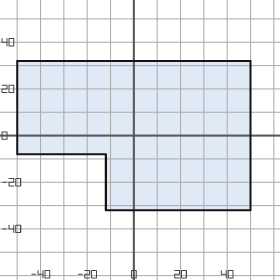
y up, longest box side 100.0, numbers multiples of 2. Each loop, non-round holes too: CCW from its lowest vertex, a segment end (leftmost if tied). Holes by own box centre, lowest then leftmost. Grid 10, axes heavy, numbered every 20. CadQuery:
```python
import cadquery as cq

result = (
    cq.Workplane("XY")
    .moveTo(-12.0, -32.0)
    .lineTo(50.0, -32.0)
    .lineTo(50.0, 32.0)
    .lineTo(-50.0, 32.0)
    .lineTo(-50.0, -8.0)
    .lineTo(-12.0, -8.0)
    .close()
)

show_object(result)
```